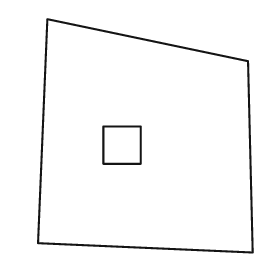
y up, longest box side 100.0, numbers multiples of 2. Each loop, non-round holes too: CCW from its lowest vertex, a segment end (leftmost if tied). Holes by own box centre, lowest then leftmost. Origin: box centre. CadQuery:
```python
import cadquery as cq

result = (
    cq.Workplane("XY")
    .moveTo(46.0, -50.0)
    .lineTo(44.0, 32.0)
    .lineTo(-42.0, 50.0)
    .lineTo(-46.0, -46.0)
    .close()
    .moveTo(-18.0, -12.0)
    .lineTo(-2.0, -12.0)
    .lineTo(-2.0, 4.0)
    .lineTo(-18.0, 4.0)
    .close()
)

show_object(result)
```